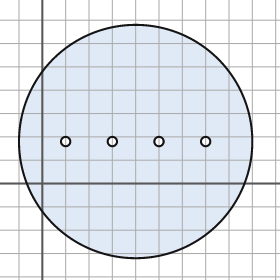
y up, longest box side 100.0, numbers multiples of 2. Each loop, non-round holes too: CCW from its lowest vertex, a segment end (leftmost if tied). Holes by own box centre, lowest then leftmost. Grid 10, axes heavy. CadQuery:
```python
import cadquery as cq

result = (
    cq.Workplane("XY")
    .moveTo(40.0, 18.0)
    .circle(50.0)
    .moveTo(10.0, 18.0)
    .circle(2.0)
    .moveTo(30.0, 18.0)
    .circle(2.0)
    .moveTo(50.0, 18.0)
    .circle(2.0)
    .moveTo(70.0, 18.0)
    .circle(2.0)
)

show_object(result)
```